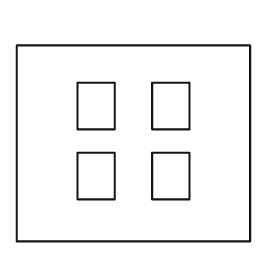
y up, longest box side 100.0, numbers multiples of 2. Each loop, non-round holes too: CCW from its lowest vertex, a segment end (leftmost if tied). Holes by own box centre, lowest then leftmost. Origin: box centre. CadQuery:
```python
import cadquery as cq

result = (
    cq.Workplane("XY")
    .moveTo(-50.0, -42.0)
    .lineTo(50.0, -42.0)
    .lineTo(50.0, 42.0)
    .lineTo(-50.0, 42.0)
    .close()
    .moveTo(-24.0, -24.0)
    .lineTo(-8.0, -24.0)
    .lineTo(-8.0, -4.0)
    .lineTo(-24.0, -4.0)
    .close()
    .moveTo(8.0, -24.0)
    .lineTo(24.0, -24.0)
    .lineTo(24.0, -4.0)
    .lineTo(8.0, -4.0)
    .close()
    .moveTo(-24.0, 6.0)
    .lineTo(-8.0, 6.0)
    .lineTo(-8.0, 26.0)
    .lineTo(-24.0, 26.0)
    .close()
    .moveTo(8.0, 6.0)
    .lineTo(24.0, 6.0)
    .lineTo(24.0, 26.0)
    .lineTo(8.0, 26.0)
    .close()
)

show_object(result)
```